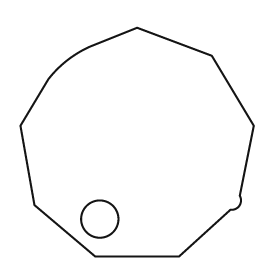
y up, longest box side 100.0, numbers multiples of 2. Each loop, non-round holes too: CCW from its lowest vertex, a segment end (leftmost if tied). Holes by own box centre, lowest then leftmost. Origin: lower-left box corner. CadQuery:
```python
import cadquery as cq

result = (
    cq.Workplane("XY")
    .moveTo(32.0, 0.0)
    .lineTo(68.0, 0.0)
    .lineTo(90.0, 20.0)
    .threePointArc((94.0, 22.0), (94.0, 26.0))
    .lineTo(100.0, 56.0)
    .lineTo(82.0, 86.0)
    .lineTo(50.0, 98.0)
    .lineTo(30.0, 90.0)
    .threePointArc((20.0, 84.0), (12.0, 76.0))
    .lineTo(0.0, 56.0)
    .lineTo(6.0, 22.0)
    .close()
    .moveTo(34.0, 16.0)
    .circle(8.0)
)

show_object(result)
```